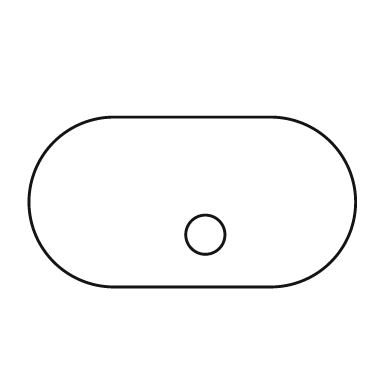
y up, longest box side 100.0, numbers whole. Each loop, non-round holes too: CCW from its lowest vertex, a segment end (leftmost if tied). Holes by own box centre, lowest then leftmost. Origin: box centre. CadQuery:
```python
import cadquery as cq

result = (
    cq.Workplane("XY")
    .moveTo(-24.0, -26.0)
    .lineTo(24.0, -26.0)
    .threePointArc((50.0, 0.0), (24.0, 26.0))
    .lineTo(-24.0, 26.0)
    .threePointArc((-50.0, 0.0), (-24.0, -26.0))
    .close()
    .moveTo(4.0, -10.0)
    .circle(6.0)
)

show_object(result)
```